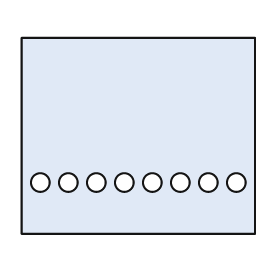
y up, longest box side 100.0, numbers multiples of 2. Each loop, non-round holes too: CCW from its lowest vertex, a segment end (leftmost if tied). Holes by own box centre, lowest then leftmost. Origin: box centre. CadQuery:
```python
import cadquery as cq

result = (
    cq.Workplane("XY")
    .moveTo(-50.0, -42.0)
    .lineTo(50.0, -42.0)
    .lineTo(50.0, 42.0)
    .lineTo(-50.0, 42.0)
    .close()
    .moveTo(-42.0, -20.0)
    .circle(4.0)
    .moveTo(-30.0, -20.0)
    .circle(4.0)
    .moveTo(-18.0, -20.0)
    .circle(4.0)
    .moveTo(-6.0, -20.0)
    .circle(4.0)
    .moveTo(6.0, -20.0)
    .circle(4.0)
    .moveTo(18.0, -20.0)
    .circle(4.0)
    .moveTo(30.0, -20.0)
    .circle(4.0)
    .moveTo(42.0, -20.0)
    .circle(4.0)
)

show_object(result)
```